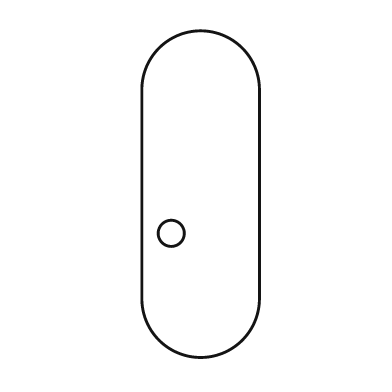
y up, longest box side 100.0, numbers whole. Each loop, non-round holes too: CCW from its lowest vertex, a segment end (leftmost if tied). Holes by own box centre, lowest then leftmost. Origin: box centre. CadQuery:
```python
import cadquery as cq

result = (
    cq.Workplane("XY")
    .moveTo(-18.0, -32.0)
    .threePointArc((0.0, -50.0), (18.0, -32.0))
    .lineTo(18.0, 32.0)
    .threePointArc((0.0, 50.0), (-18.0, 32.0))
    .close()
    .moveTo(-9.0, -12.0)
    .circle(4.0)
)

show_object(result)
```